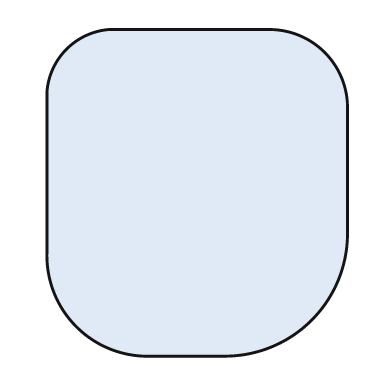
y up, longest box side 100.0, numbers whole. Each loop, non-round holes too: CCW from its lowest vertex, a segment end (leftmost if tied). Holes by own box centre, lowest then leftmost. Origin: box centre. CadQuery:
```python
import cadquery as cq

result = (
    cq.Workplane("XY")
    .moveTo(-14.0, -50.0)
    .lineTo(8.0, -50.0)
    .threePointArc((35.0, -39.0), (46.0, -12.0))
    .lineTo(46.0, 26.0)
    .threePointArc((39.0, 43.0), (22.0, 50.0))
    .lineTo(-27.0, 50.0)
    .threePointArc((-40.0, 44.0), (-46.0, 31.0))
    .lineTo(-46.0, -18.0)
    .threePointArc((-37.0, -41.0), (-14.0, -50.0))
    .close()
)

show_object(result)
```